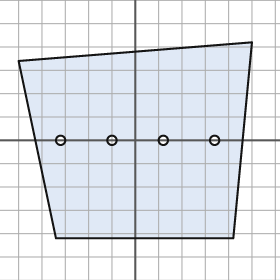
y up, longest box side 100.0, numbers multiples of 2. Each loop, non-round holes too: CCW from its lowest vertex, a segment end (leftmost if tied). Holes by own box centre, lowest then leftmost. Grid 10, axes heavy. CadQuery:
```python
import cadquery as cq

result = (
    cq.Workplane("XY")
    .moveTo(-34.0, -42.0)
    .lineTo(42.0, -42.0)
    .lineTo(50.0, 42.0)
    .lineTo(-50.0, 34.0)
    .close()
    .moveTo(-32.0, 0.0)
    .circle(2.0)
    .moveTo(-10.0, 0.0)
    .circle(2.0)
    .moveTo(12.0, 0.0)
    .circle(2.0)
    .moveTo(34.0, 0.0)
    .circle(2.0)
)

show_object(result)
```